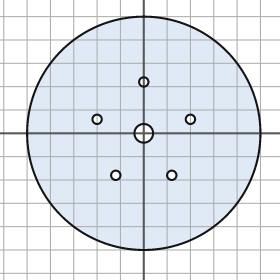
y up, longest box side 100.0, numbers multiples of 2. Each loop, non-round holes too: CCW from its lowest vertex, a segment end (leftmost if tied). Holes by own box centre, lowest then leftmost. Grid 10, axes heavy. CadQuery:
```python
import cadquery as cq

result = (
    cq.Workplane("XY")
    .moveTo(0.0, 0.0)
    .circle(50.0)
    .moveTo(-12.0, -18.0)
    .circle(2.0)
    .moveTo(12.0, -18.0)
    .circle(2.0)
    .moveTo(0.0, 0.0)
    .circle(4.0)
    .moveTo(-20.0, 6.0)
    .circle(2.0)
    .moveTo(20.0, 6.0)
    .circle(2.0)
    .moveTo(0.0, 22.0)
    .circle(2.0)
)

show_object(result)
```